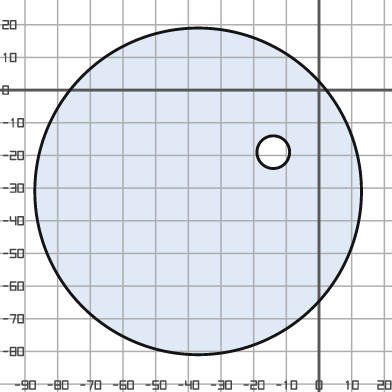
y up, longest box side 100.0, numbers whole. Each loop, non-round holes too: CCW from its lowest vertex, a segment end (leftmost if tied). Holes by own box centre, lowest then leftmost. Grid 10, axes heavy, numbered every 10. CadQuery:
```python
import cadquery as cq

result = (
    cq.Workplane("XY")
    .moveTo(-37.0, -31.0)
    .circle(50.0)
    .moveTo(-14.0, -19.0)
    .circle(5.0)
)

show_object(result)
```